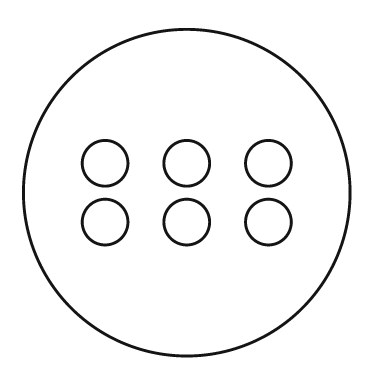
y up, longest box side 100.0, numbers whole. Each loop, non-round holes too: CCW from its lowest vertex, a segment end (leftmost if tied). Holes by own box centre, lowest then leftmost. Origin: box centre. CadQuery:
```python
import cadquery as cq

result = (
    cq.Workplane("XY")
    .moveTo(0.0, 0.0)
    .circle(50.0)
    .moveTo(-25.0, -9.0)
    .circle(7.0)
    .moveTo(0.0, -9.0)
    .circle(7.0)
    .moveTo(25.0, -9.0)
    .circle(7.0)
    .moveTo(-25.0, 9.0)
    .circle(7.0)
    .moveTo(0.0, 9.0)
    .circle(7.0)
    .moveTo(25.0, 9.0)
    .circle(7.0)
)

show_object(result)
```